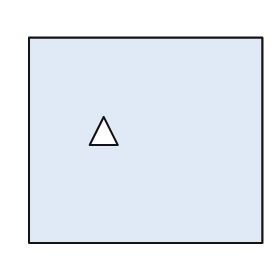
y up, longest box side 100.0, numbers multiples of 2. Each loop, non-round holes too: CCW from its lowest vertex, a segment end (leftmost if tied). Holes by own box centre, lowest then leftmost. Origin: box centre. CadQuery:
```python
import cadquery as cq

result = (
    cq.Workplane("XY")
    .moveTo(-50.0, -44.0)
    .lineTo(50.0, -44.0)
    .lineTo(50.0, 44.0)
    .lineTo(-50.0, 44.0)
    .close()
    .moveTo(-24.0, -2.0)
    .lineTo(-12.0, -2.0)
    .lineTo(-18.0, 10.0)
    .close()
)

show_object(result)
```